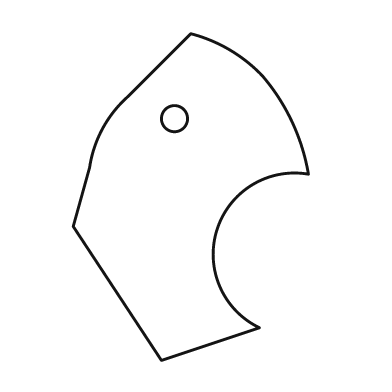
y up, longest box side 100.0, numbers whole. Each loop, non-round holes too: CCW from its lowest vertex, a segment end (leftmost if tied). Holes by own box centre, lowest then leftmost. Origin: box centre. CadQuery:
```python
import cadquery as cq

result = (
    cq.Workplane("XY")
    .moveTo(-9.0, -50.0)
    .lineTo(21.0, -40.0)
    .threePointArc((8.0, -10.0), (36.0, 7.0))
    .threePointArc((31.0, 23.0), (22.0, 37.0))
    .threePointArc((12.0, 45.0), (0.0, 50.0))
    .lineTo(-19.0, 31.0)
    .threePointArc((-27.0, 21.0), (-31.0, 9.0))
    .lineTo(-36.0, -9.0)
    .close()
    .moveTo(-5.0, 24.0)
    .circle(4.0)
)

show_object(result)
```